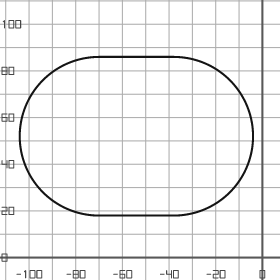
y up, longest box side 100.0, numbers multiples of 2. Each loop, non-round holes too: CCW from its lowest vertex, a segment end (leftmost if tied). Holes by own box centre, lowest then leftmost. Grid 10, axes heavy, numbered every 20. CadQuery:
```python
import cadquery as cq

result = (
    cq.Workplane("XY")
    .moveTo(-70.0, 18.0)
    .lineTo(-38.0, 18.0)
    .threePointArc((-4.0, 52.0), (-38.0, 86.0))
    .lineTo(-70.0, 86.0)
    .threePointArc((-104.0, 52.0), (-70.0, 18.0))
    .close()
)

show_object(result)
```